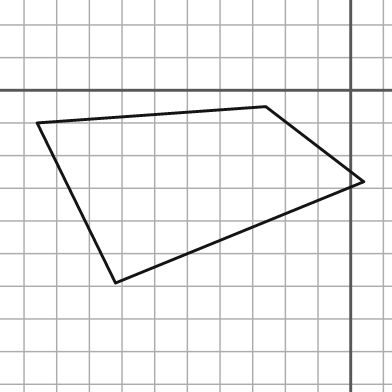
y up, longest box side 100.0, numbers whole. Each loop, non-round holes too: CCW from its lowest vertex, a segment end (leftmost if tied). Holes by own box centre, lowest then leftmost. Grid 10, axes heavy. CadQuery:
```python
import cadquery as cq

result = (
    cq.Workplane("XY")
    .moveTo(-72.0, -59.0)
    .lineTo(4.0, -28.0)
    .lineTo(-26.0, -5.0)
    .lineTo(-96.0, -10.0)
    .close()
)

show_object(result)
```